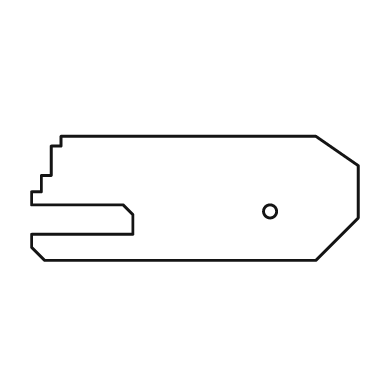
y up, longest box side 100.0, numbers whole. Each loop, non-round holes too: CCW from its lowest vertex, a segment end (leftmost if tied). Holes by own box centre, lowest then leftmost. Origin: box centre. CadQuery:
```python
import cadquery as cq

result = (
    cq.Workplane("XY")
    .moveTo(-46.0, -19.0)
    .lineTo(37.0, -19.0)
    .lineTo(50.0, -6.0)
    .lineTo(50.0, 10.0)
    .lineTo(37.0, 19.0)
    .lineTo(-41.0, 19.0)
    .lineTo(-41.0, 16.0)
    .lineTo(-44.0, 16.0)
    .lineTo(-44.0, 7.0)
    .lineTo(-47.0, 7.0)
    .lineTo(-47.0, 2.0)
    .lineTo(-50.0, 2.0)
    .lineTo(-50.0, -2.0)
    .lineTo(-22.0, -2.0)
    .lineTo(-19.0, -5.0)
    .lineTo(-19.0, -11.0)
    .lineTo(-50.0, -11.0)
    .lineTo(-50.0, -15.0)
    .close()
    .moveTo(23.0, -4.0)
    .circle(2.0)
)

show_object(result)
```